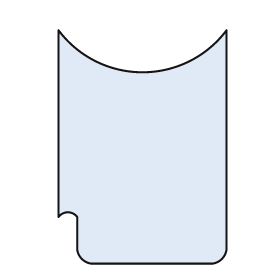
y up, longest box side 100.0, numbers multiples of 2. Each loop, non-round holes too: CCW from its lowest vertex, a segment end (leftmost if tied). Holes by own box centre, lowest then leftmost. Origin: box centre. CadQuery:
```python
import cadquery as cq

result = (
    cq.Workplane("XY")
    .moveTo(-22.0, -50.0)
    .lineTo(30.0, -50.0)
    .threePointArc((34.0, -48.0), (36.0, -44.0))
    .lineTo(36.0, 50.0)
    .threePointArc((0.0, 32.0), (-36.0, 50.0))
    .lineTo(-36.0, -30.0)
    .threePointArc((-32.0, -28.0), (-28.0, -30.0))
    .lineTo(-28.0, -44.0)
    .threePointArc((-26.0, -48.0), (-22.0, -50.0))
    .close()
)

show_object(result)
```